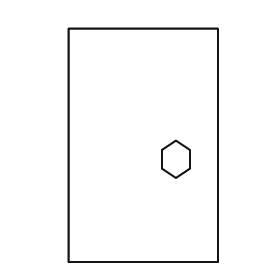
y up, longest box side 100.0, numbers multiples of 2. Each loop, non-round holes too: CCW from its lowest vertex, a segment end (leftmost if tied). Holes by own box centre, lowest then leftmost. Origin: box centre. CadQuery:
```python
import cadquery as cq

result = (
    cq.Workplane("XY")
    .moveTo(-32.0, -50.0)
    .lineTo(32.0, -50.0)
    .lineTo(32.0, 50.0)
    .lineTo(-32.0, 50.0)
    .close()
    .moveTo(14.0, -14.0)
    .lineTo(20.0, -10.0)
    .lineTo(20.0, -2.0)
    .lineTo(14.0, 2.0)
    .lineTo(8.0, -2.0)
    .lineTo(8.0, -10.0)
    .close()
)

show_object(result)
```